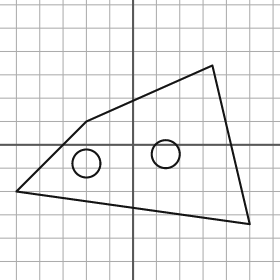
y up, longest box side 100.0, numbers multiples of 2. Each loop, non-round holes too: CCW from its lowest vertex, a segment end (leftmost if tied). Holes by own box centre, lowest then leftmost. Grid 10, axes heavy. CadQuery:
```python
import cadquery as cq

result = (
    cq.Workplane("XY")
    .moveTo(50.0, -34.0)
    .lineTo(34.0, 34.0)
    .lineTo(-20.0, 10.0)
    .lineTo(-50.0, -20.0)
    .close()
    .moveTo(-20.0, -8.0)
    .circle(6.0)
    .moveTo(14.0, -4.0)
    .circle(6.0)
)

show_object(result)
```